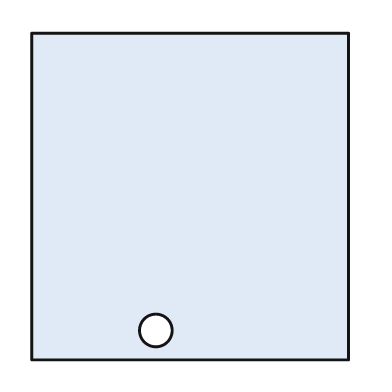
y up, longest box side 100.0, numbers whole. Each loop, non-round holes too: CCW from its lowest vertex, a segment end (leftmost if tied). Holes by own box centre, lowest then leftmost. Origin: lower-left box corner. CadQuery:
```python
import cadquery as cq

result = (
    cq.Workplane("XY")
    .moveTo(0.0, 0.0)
    .lineTo(97.0, 0.0)
    .lineTo(97.0, 100.0)
    .lineTo(0.0, 100.0)
    .close()
    .moveTo(38.0, 9.0)
    .circle(5.0)
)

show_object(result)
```